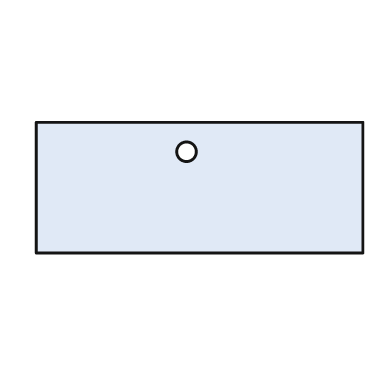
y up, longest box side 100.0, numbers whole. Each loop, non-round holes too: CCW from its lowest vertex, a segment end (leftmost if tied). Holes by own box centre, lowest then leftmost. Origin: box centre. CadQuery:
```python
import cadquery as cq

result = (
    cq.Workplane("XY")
    .moveTo(-50.0, -20.0)
    .lineTo(50.0, -20.0)
    .lineTo(50.0, 20.0)
    .lineTo(-50.0, 20.0)
    .close()
    .moveTo(-4.0, 11.0)
    .circle(3.0)
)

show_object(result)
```